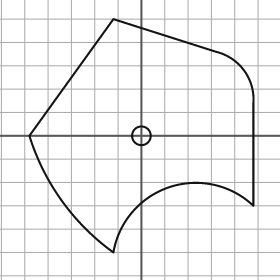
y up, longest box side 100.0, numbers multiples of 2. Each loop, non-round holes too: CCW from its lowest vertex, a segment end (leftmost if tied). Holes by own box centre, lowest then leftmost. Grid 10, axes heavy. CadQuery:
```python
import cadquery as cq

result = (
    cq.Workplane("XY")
    .moveTo(-12.0, -50.0)
    .threePointArc((12.0, -22.0), (48.0, -30.0))
    .lineTo(48.0, 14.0)
    .threePointArc((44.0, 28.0), (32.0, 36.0))
    .lineTo(-12.0, 50.0)
    .lineTo(-48.0, 0.0)
    .threePointArc((-34.0, -28.0), (-12.0, -50.0))
    .close()
    .moveTo(0.0, 0.0)
    .circle(4.0)
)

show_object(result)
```